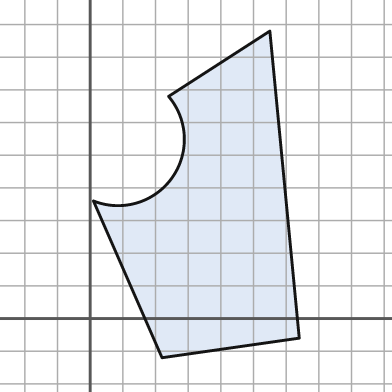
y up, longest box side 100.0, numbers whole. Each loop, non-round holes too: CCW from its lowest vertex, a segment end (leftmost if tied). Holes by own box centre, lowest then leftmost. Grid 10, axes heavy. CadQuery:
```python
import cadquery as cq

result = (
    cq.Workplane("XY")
    .moveTo(22.0, -12.0)
    .lineTo(64.0, -6.0)
    .lineTo(55.0, 88.0)
    .lineTo(24.0, 68.0)
    .threePointArc((25.0, 43.0), (1.0, 36.0))
    .close()
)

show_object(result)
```